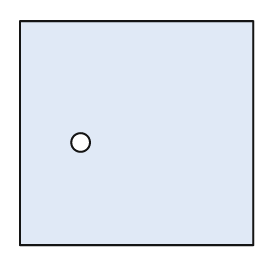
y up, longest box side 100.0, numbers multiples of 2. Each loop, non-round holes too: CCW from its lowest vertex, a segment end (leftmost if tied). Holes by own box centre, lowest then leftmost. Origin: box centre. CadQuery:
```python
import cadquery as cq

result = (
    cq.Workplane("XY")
    .moveTo(-50.0, -48.0)
    .lineTo(50.0, -48.0)
    .lineTo(50.0, 48.0)
    .lineTo(-50.0, 48.0)
    .close()
    .moveTo(-24.0, -4.0)
    .circle(4.0)
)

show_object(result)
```